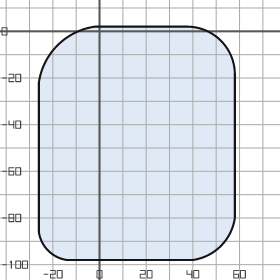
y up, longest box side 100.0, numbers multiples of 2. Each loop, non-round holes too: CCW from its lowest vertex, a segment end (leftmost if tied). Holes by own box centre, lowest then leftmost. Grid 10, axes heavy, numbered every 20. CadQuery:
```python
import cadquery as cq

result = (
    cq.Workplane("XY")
    .moveTo(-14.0, -98.0)
    .lineTo(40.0, -98.0)
    .threePointArc((52.0, -92.0), (58.0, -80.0))
    .lineTo(58.0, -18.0)
    .threePointArc((52.0, -4.0), (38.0, 2.0))
    .lineTo(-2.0, 2.0)
    .threePointArc((-18.0, -6.0), (-26.0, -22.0))
    .lineTo(-26.0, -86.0)
    .threePointArc((-22.0, -94.0), (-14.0, -98.0))
    .close()
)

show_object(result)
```